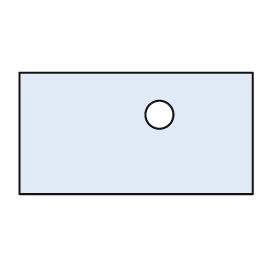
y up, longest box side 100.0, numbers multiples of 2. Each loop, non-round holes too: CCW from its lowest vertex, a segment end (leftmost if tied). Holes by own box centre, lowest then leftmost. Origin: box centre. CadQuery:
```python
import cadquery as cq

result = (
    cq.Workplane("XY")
    .moveTo(-50.0, -26.0)
    .lineTo(50.0, -26.0)
    .lineTo(50.0, 26.0)
    .lineTo(-50.0, 26.0)
    .close()
    .moveTo(10.0, 8.0)
    .circle(6.0)
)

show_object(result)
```